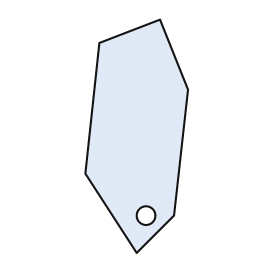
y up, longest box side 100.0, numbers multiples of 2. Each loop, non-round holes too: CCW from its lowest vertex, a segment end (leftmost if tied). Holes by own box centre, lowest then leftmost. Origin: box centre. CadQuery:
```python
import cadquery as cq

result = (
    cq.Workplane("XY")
    .moveTo(0.0, -50.0)
    .lineTo(16.0, -34.0)
    .lineTo(22.0, 20.0)
    .lineTo(10.0, 50.0)
    .lineTo(-16.0, 40.0)
    .lineTo(-22.0, -16.0)
    .close()
    .moveTo(4.0, -34.0)
    .circle(4.0)
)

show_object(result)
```